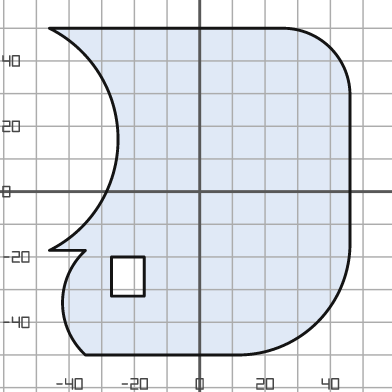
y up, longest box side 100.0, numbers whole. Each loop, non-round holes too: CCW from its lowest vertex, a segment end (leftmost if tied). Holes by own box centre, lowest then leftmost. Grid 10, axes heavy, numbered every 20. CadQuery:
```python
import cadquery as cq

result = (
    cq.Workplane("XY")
    .moveTo(-35.0, -50.0)
    .lineTo(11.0, -50.0)
    .threePointArc((36.0, -40.0), (46.0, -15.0))
    .lineTo(46.0, 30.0)
    .threePointArc((40.0, 44.0), (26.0, 50.0))
    .lineTo(-46.0, 50.0)
    .threePointArc((-25.0, 16.0), (-46.0, -18.0))
    .lineTo(-35.0, -18.0)
    .threePointArc((-42.0, -34.0), (-35.0, -50.0))
    .close()
    .moveTo(-27.0, -32.0)
    .lineTo(-17.0, -32.0)
    .lineTo(-17.0, -20.0)
    .lineTo(-27.0, -20.0)
    .close()
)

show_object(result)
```